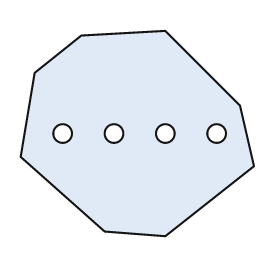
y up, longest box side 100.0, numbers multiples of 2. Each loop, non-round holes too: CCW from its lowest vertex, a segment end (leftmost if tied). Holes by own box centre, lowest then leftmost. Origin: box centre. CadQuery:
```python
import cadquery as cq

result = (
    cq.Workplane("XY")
    .moveTo(12.0, -44.0)
    .lineTo(50.0, -14.0)
    .lineTo(44.0, 12.0)
    .lineTo(12.0, 44.0)
    .lineTo(-24.0, 42.0)
    .lineTo(-44.0, 26.0)
    .lineTo(-50.0, -10.0)
    .lineTo(-14.0, -42.0)
    .close()
    .moveTo(-32.0, 0.0)
    .circle(4.0)
    .moveTo(-10.0, 0.0)
    .circle(4.0)
    .moveTo(12.0, 0.0)
    .circle(4.0)
    .moveTo(34.0, 0.0)
    .circle(4.0)
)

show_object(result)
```